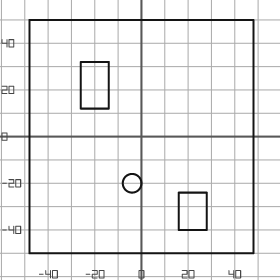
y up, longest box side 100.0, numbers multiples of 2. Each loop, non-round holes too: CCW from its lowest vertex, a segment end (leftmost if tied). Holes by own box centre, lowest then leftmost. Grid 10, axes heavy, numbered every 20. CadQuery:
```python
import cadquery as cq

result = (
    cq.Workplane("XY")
    .moveTo(-48.0, -50.0)
    .lineTo(48.0, -50.0)
    .lineTo(48.0, 50.0)
    .lineTo(-48.0, 50.0)
    .close()
    .moveTo(16.0, -40.0)
    .lineTo(28.0, -40.0)
    .lineTo(28.0, -24.0)
    .lineTo(16.0, -24.0)
    .close()
    .moveTo(-4.0, -20.0)
    .circle(4.0)
    .moveTo(-26.0, 12.0)
    .lineTo(-14.0, 12.0)
    .lineTo(-14.0, 32.0)
    .lineTo(-26.0, 32.0)
    .close()
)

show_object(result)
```